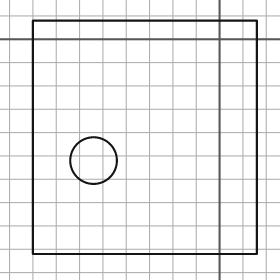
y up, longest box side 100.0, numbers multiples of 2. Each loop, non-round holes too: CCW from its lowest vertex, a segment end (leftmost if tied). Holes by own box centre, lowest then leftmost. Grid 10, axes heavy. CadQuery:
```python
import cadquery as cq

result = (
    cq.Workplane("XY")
    .moveTo(-80.0, -92.0)
    .lineTo(16.0, -92.0)
    .lineTo(16.0, 8.0)
    .lineTo(-80.0, 8.0)
    .close()
    .moveTo(-54.0, -52.0)
    .circle(10.0)
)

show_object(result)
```